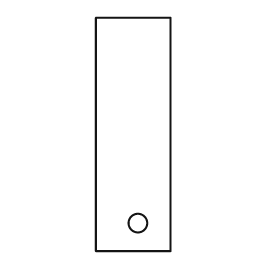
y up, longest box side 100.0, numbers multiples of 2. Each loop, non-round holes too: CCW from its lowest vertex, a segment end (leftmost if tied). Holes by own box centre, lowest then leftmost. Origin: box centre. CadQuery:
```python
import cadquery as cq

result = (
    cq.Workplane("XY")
    .moveTo(-16.0, -50.0)
    .lineTo(16.0, -50.0)
    .lineTo(16.0, 50.0)
    .lineTo(-16.0, 50.0)
    .close()
    .moveTo(2.0, -38.0)
    .circle(4.0)
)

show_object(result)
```